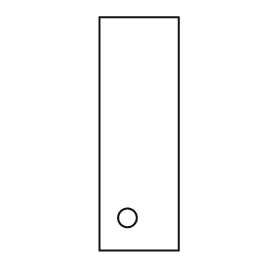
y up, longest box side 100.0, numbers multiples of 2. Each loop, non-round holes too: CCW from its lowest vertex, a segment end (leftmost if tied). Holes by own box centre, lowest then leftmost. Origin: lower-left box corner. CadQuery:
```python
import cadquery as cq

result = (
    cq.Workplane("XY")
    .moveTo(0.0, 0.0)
    .lineTo(34.0, 0.0)
    .lineTo(34.0, 100.0)
    .lineTo(0.0, 100.0)
    .close()
    .moveTo(12.0, 14.0)
    .circle(4.0)
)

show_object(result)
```